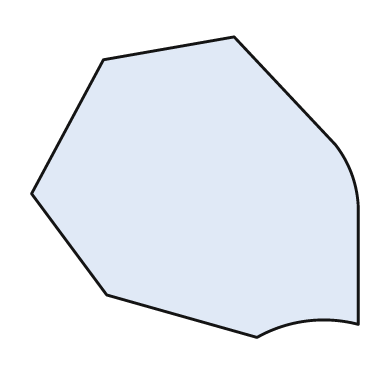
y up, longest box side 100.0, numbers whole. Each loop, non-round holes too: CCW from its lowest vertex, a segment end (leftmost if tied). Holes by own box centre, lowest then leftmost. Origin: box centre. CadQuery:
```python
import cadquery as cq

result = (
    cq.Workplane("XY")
    .moveTo(19.0, -46.0)
    .threePointArc((34.0, -41.0), (50.0, -42.0))
    .lineTo(50.0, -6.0)
    .threePointArc((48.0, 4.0), (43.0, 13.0))
    .lineTo(12.0, 46.0)
    .lineTo(-28.0, 39.0)
    .lineTo(-50.0, -2.0)
    .lineTo(-27.0, -33.0)
    .close()
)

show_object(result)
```